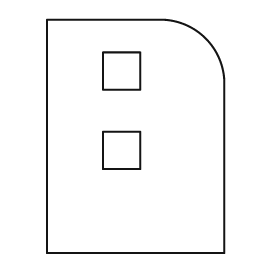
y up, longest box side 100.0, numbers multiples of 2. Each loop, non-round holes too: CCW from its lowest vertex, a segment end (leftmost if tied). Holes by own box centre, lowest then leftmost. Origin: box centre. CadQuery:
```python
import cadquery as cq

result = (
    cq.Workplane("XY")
    .moveTo(-38.0, -50.0)
    .lineTo(38.0, -50.0)
    .lineTo(38.0, 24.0)
    .threePointArc((30.0, 42.0), (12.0, 50.0))
    .lineTo(-38.0, 50.0)
    .close()
    .moveTo(-14.0, -14.0)
    .lineTo(2.0, -14.0)
    .lineTo(2.0, 2.0)
    .lineTo(-14.0, 2.0)
    .close()
    .moveTo(-14.0, 20.0)
    .lineTo(2.0, 20.0)
    .lineTo(2.0, 36.0)
    .lineTo(-14.0, 36.0)
    .close()
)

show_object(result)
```